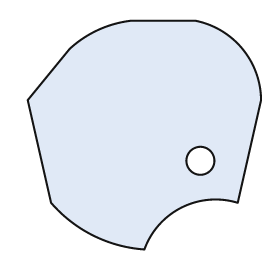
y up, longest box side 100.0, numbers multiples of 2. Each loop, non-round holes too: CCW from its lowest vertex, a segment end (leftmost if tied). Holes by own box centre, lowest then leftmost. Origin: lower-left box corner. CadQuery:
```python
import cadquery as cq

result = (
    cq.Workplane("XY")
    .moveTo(50.0, 0.0)
    .threePointArc((66.0, 18.0), (90.0, 20.0))
    .lineTo(100.0, 64.0)
    .threePointArc((92.0, 86.0), (72.0, 98.0))
    .lineTo(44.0, 98.0)
    .threePointArc((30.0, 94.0), (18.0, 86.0))
    .lineTo(0.0, 64.0)
    .lineTo(10.0, 20.0)
    .threePointArc((28.0, 6.0), (50.0, 0.0))
    .close()
    .moveTo(74.0, 38.0)
    .circle(6.0)
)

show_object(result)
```